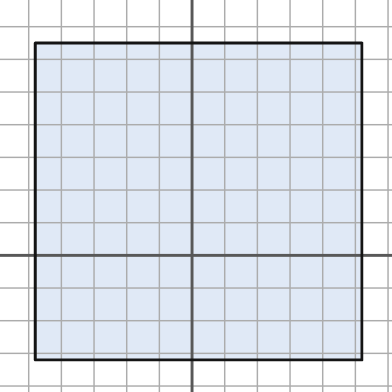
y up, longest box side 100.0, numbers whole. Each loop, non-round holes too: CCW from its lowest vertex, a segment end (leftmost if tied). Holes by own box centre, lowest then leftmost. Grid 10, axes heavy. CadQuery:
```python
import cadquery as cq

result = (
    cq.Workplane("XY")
    .moveTo(-48.0, -32.0)
    .lineTo(52.0, -32.0)
    .lineTo(52.0, 65.0)
    .lineTo(-48.0, 65.0)
    .close()
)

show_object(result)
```